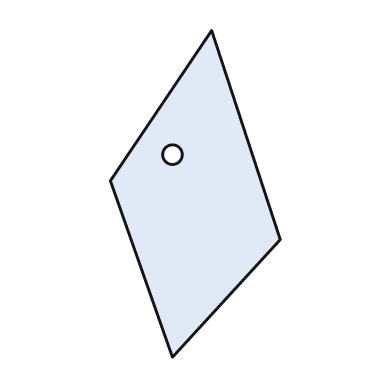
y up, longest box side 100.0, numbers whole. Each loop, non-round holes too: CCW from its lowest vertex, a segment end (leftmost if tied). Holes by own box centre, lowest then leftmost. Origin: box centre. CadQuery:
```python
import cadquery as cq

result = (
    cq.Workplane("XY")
    .moveTo(-7.0, -50.0)
    .lineTo(26.0, -14.0)
    .lineTo(5.0, 50.0)
    .lineTo(-26.0, 4.0)
    .close()
    .moveTo(-7.0, 12.0)
    .circle(3.0)
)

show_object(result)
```